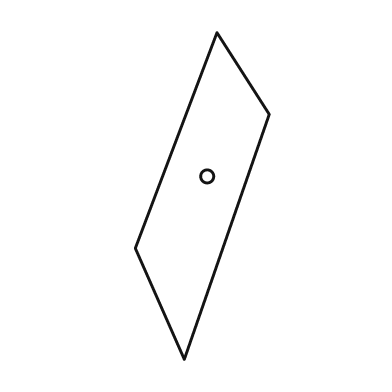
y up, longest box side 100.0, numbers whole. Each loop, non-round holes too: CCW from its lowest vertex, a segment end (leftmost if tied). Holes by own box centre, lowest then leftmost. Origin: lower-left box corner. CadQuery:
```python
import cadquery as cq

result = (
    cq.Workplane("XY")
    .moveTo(15.0, 0.0)
    .lineTo(41.0, 75.0)
    .lineTo(25.0, 100.0)
    .lineTo(0.0, 34.0)
    .close()
    .moveTo(22.0, 56.0)
    .circle(2.0)
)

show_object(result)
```